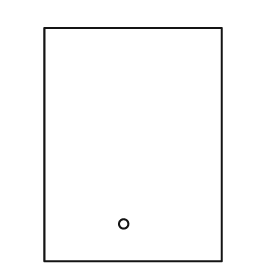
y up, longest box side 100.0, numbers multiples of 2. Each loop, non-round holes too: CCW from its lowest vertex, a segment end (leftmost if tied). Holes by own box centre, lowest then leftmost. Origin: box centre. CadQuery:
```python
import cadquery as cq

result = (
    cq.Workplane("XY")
    .moveTo(-38.0, -50.0)
    .lineTo(38.0, -50.0)
    .lineTo(38.0, 50.0)
    .lineTo(-38.0, 50.0)
    .close()
    .moveTo(-4.0, -34.0)
    .circle(2.0)
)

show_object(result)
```